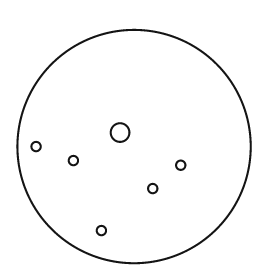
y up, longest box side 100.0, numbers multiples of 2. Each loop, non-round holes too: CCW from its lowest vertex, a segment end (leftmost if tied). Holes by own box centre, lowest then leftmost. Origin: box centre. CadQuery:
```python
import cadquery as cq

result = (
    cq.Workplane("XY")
    .moveTo(0.0, 0.0)
    .circle(50.0)
    .moveTo(-14.0, -36.0)
    .circle(2.0)
    .moveTo(8.0, -18.0)
    .circle(2.0)
    .moveTo(20.0, -8.0)
    .circle(2.0)
    .moveTo(-26.0, -6.0)
    .circle(2.0)
    .moveTo(-42.0, 0.0)
    .circle(2.0)
    .moveTo(-6.0, 6.0)
    .circle(4.0)
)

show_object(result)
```